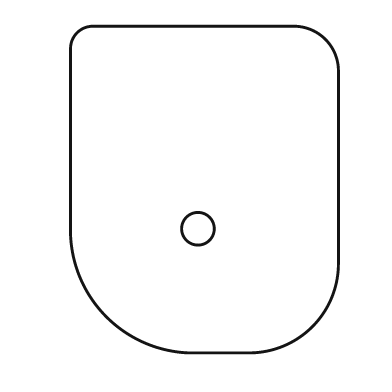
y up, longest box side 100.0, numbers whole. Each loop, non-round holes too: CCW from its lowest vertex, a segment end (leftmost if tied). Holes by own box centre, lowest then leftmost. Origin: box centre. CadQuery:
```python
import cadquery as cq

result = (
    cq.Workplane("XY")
    .moveTo(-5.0, -50.0)
    .lineTo(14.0, -50.0)
    .threePointArc((33.0, -42.0), (41.0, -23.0))
    .lineTo(41.0, 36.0)
    .threePointArc((37.0, 46.0), (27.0, 50.0))
    .lineTo(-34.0, 50.0)
    .threePointArc((-39.0, 48.0), (-41.0, 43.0))
    .lineTo(-41.0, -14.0)
    .threePointArc((-30.0, -39.0), (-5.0, -50.0))
    .close()
    .moveTo(-2.0, -12.0)
    .circle(5.0)
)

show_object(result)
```